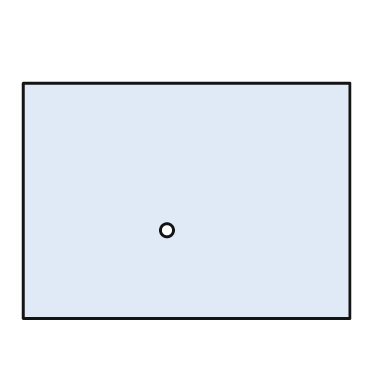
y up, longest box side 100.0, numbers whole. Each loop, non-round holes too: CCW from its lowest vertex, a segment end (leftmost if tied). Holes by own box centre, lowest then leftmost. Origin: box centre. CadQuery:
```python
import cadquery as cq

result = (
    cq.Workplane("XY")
    .moveTo(-50.0, -36.0)
    .lineTo(50.0, -36.0)
    .lineTo(50.0, 36.0)
    .lineTo(-50.0, 36.0)
    .close()
    .moveTo(-6.0, -9.0)
    .circle(2.0)
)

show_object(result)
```